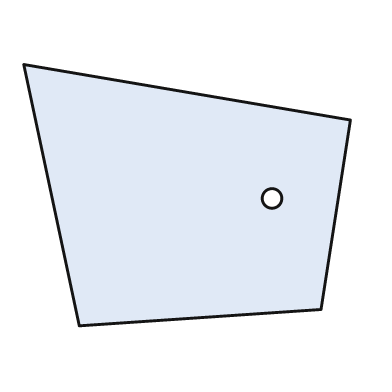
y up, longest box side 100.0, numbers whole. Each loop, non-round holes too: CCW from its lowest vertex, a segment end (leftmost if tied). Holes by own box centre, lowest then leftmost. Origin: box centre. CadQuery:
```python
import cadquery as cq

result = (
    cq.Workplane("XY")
    .moveTo(-33.0, -40.0)
    .lineTo(41.0, -35.0)
    .lineTo(50.0, 23.0)
    .lineTo(-50.0, 40.0)
    .close()
    .moveTo(26.0, -1.0)
    .circle(3.0)
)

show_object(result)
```